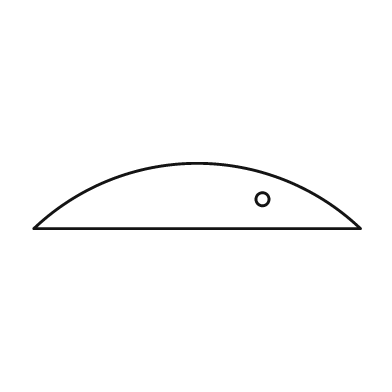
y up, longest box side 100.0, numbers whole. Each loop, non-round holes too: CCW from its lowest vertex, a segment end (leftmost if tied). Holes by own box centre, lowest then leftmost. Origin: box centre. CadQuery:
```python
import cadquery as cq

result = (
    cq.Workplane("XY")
    .moveTo(-50.0, -10.0)
    .lineTo(50.0, -10.0)
    .threePointArc((0.0, 10.0), (-50.0, -10.0))
    .close()
    .moveTo(20.0, -1.0)
    .circle(2.0)
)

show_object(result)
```